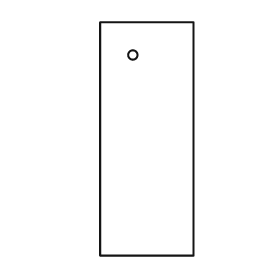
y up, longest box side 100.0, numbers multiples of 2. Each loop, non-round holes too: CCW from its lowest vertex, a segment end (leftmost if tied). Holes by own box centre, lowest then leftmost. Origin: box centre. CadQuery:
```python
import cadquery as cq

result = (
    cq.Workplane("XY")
    .moveTo(-20.0, -50.0)
    .lineTo(20.0, -50.0)
    .lineTo(20.0, 50.0)
    .lineTo(-20.0, 50.0)
    .close()
    .moveTo(-6.0, 36.0)
    .circle(2.0)
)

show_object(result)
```